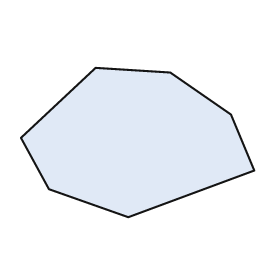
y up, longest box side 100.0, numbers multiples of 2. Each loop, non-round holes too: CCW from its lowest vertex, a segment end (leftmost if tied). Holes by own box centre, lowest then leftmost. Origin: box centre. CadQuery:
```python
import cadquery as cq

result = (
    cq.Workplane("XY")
    .moveTo(-4.0, -32.0)
    .lineTo(50.0, -12.0)
    .lineTo(40.0, 12.0)
    .lineTo(14.0, 30.0)
    .lineTo(-18.0, 32.0)
    .lineTo(-50.0, 2.0)
    .lineTo(-38.0, -20.0)
    .close()
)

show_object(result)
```